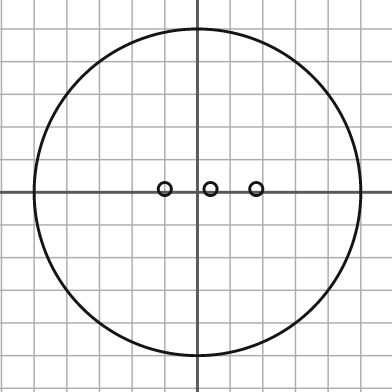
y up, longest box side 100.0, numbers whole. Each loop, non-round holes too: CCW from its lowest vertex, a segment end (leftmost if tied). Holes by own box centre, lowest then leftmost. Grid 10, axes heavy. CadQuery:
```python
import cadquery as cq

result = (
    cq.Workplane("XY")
    .moveTo(0.0, 0.0)
    .circle(50.0)
    .moveTo(-10.0, 1.0)
    .circle(2.0)
    .moveTo(4.0, 1.0)
    .circle(2.0)
    .moveTo(18.0, 1.0)
    .circle(2.0)
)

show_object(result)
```